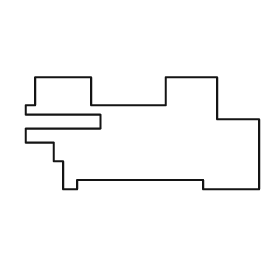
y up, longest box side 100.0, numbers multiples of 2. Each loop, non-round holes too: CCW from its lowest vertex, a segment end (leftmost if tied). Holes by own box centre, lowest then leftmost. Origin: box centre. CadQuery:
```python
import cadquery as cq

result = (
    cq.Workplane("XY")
    .moveTo(-34.0, -24.0)
    .lineTo(-28.0, -24.0)
    .lineTo(-28.0, -20.0)
    .lineTo(26.0, -20.0)
    .lineTo(26.0, -24.0)
    .lineTo(50.0, -24.0)
    .lineTo(50.0, 6.0)
    .lineTo(32.0, 6.0)
    .lineTo(32.0, 24.0)
    .lineTo(10.0, 24.0)
    .lineTo(10.0, 12.0)
    .lineTo(-22.0, 12.0)
    .lineTo(-22.0, 24.0)
    .lineTo(-46.0, 24.0)
    .lineTo(-46.0, 12.0)
    .lineTo(-50.0, 12.0)
    .lineTo(-50.0, 8.0)
    .lineTo(-18.0, 8.0)
    .lineTo(-18.0, 2.0)
    .lineTo(-50.0, 2.0)
    .lineTo(-50.0, -4.0)
    .lineTo(-38.0, -4.0)
    .lineTo(-38.0, -12.0)
    .lineTo(-34.0, -12.0)
    .close()
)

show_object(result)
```